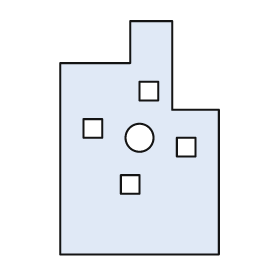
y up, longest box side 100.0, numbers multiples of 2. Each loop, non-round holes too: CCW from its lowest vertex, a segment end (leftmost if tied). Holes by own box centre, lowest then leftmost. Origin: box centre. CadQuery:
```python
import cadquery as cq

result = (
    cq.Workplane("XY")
    .moveTo(-34.0, -50.0)
    .lineTo(34.0, -50.0)
    .lineTo(34.0, 12.0)
    .lineTo(14.0, 12.0)
    .lineTo(14.0, 50.0)
    .lineTo(-4.0, 50.0)
    .lineTo(-4.0, 32.0)
    .lineTo(-34.0, 32.0)
    .close()
    .moveTo(-8.0, -24.0)
    .lineTo(0.0, -24.0)
    .lineTo(0.0, -16.0)
    .lineTo(-8.0, -16.0)
    .close()
    .moveTo(16.0, -8.0)
    .lineTo(24.0, -8.0)
    .lineTo(24.0, 0.0)
    .lineTo(16.0, 0.0)
    .close()
    .moveTo(0.0, 0.0)
    .circle(6.0)
    .moveTo(-24.0, 0.0)
    .lineTo(-16.0, 0.0)
    .lineTo(-16.0, 8.0)
    .lineTo(-24.0, 8.0)
    .close()
    .moveTo(0.0, 16.0)
    .lineTo(8.0, 16.0)
    .lineTo(8.0, 24.0)
    .lineTo(0.0, 24.0)
    .close()
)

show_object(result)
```